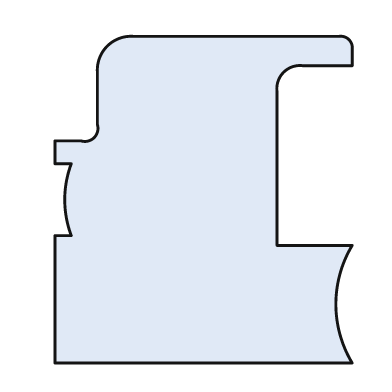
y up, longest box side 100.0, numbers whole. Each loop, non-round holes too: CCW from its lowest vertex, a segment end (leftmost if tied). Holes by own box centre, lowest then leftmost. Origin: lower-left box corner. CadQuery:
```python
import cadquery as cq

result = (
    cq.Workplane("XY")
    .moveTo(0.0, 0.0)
    .lineTo(91.0, 0.0)
    .threePointArc((86.0, 18.0), (91.0, 36.0))
    .lineTo(68.0, 36.0)
    .lineTo(68.0, 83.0)
    .threePointArc((70.0, 89.0), (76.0, 91.0))
    .lineTo(91.0, 91.0)
    .lineTo(91.0, 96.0)
    .threePointArc((90.0, 99.0), (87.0, 100.0))
    .lineTo(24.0, 100.0)
    .threePointArc((16.0, 97.0), (13.0, 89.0))
    .lineTo(13.0, 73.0)
    .threePointArc((12.0, 69.0), (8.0, 68.0))
    .lineTo(0.0, 68.0)
    .lineTo(0.0, 61.0)
    .lineTo(5.0, 61.0)
    .threePointArc((3.0, 50.0), (5.0, 39.0))
    .lineTo(0.0, 39.0)
    .close()
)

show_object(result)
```